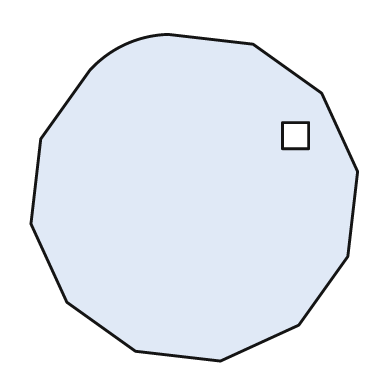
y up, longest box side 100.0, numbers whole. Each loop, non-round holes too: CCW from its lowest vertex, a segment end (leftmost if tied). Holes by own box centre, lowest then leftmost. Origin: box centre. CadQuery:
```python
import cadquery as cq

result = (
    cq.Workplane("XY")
    .moveTo(8.0, -50.0)
    .lineTo(32.0, -39.0)
    .lineTo(47.0, -18.0)
    .lineTo(50.0, 8.0)
    .lineTo(39.0, 32.0)
    .lineTo(18.0, 47.0)
    .lineTo(-8.0, 50.0)
    .threePointArc((-21.0, 47.0), (-32.0, 39.0))
    .lineTo(-47.0, 18.0)
    .lineTo(-50.0, -8.0)
    .lineTo(-39.0, -32.0)
    .lineTo(-18.0, -47.0)
    .close()
    .moveTo(27.0, 15.0)
    .lineTo(35.0, 15.0)
    .lineTo(35.0, 23.0)
    .lineTo(27.0, 23.0)
    .close()
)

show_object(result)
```